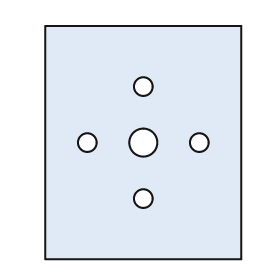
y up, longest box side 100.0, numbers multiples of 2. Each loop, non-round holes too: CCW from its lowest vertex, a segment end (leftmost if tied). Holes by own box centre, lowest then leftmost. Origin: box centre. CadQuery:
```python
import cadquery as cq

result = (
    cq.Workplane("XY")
    .moveTo(-42.0, -50.0)
    .lineTo(42.0, -50.0)
    .lineTo(42.0, 50.0)
    .lineTo(-42.0, 50.0)
    .close()
    .moveTo(0.0, -24.0)
    .circle(4.0)
    .moveTo(-24.0, 0.0)
    .circle(4.0)
    .moveTo(0.0, 0.0)
    .circle(6.0)
    .moveTo(24.0, 0.0)
    .circle(4.0)
    .moveTo(0.0, 24.0)
    .circle(4.0)
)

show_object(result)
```